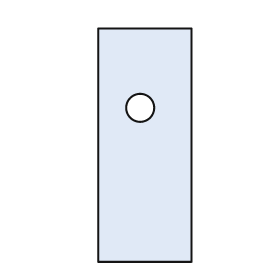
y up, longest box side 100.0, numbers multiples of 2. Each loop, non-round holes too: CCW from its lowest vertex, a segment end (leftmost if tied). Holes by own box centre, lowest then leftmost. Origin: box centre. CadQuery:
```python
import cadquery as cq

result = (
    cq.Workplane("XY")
    .moveTo(-20.0, -50.0)
    .lineTo(20.0, -50.0)
    .lineTo(20.0, 50.0)
    .lineTo(-20.0, 50.0)
    .close()
    .moveTo(-2.0, 16.0)
    .circle(6.0)
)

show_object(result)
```